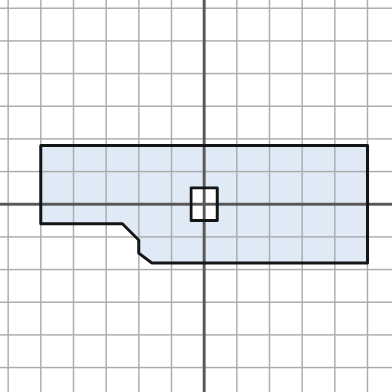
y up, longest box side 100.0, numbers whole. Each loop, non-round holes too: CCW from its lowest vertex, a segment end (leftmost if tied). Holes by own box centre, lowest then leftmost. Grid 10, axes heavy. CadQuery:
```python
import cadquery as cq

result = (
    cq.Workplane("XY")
    .moveTo(-16.0, -18.0)
    .lineTo(50.0, -18.0)
    .lineTo(50.0, 18.0)
    .lineTo(-50.0, 18.0)
    .lineTo(-50.0, -6.0)
    .lineTo(-25.0, -6.0)
    .lineTo(-20.0, -11.0)
    .lineTo(-20.0, -15.0)
    .close()
    .moveTo(-4.0, -5.0)
    .lineTo(4.0, -5.0)
    .lineTo(4.0, 5.0)
    .lineTo(-4.0, 5.0)
    .close()
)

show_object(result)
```